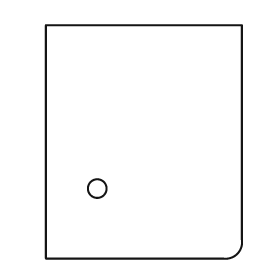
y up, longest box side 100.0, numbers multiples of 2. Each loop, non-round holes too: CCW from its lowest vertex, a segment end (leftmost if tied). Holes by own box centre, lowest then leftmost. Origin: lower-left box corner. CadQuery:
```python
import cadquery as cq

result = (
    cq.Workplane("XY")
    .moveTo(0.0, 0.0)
    .lineTo(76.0, 0.0)
    .threePointArc((82.0, 2.0), (84.0, 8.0))
    .lineTo(84.0, 100.0)
    .lineTo(0.0, 100.0)
    .close()
    .moveTo(22.0, 30.0)
    .circle(4.0)
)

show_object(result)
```